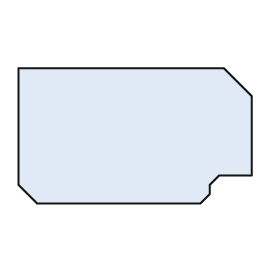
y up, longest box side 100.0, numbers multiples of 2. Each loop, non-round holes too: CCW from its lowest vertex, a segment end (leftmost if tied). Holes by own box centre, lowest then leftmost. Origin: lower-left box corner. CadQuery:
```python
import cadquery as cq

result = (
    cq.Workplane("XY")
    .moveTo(8.0, 0.0)
    .lineTo(78.0, 0.0)
    .lineTo(82.0, 4.0)
    .lineTo(82.0, 8.0)
    .lineTo(86.0, 12.0)
    .lineTo(100.0, 12.0)
    .lineTo(100.0, 46.0)
    .lineTo(88.0, 58.0)
    .lineTo(0.0, 58.0)
    .lineTo(0.0, 8.0)
    .close()
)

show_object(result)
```